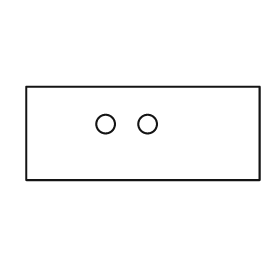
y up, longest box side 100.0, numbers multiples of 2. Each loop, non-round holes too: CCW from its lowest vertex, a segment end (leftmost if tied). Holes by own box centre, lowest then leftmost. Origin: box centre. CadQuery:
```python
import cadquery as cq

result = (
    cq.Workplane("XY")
    .moveTo(-50.0, -20.0)
    .lineTo(50.0, -20.0)
    .lineTo(50.0, 20.0)
    .lineTo(-50.0, 20.0)
    .close()
    .moveTo(-16.0, 4.0)
    .circle(4.0)
    .moveTo(2.0, 4.0)
    .circle(4.0)
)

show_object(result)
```